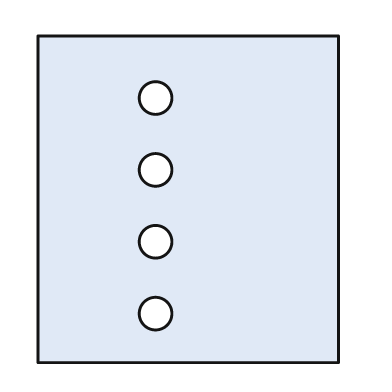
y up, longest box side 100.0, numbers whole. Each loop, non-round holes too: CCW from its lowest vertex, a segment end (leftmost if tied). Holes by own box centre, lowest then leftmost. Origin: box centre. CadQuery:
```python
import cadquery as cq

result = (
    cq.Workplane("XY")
    .moveTo(-46.0, -50.0)
    .lineTo(46.0, -50.0)
    .lineTo(46.0, 50.0)
    .lineTo(-46.0, 50.0)
    .close()
    .moveTo(-10.0, -35.0)
    .circle(5.0)
    .moveTo(-10.0, -13.0)
    .circle(5.0)
    .moveTo(-10.0, 9.0)
    .circle(5.0)
    .moveTo(-10.0, 31.0)
    .circle(5.0)
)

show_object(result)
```